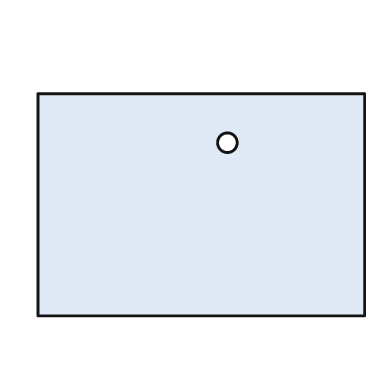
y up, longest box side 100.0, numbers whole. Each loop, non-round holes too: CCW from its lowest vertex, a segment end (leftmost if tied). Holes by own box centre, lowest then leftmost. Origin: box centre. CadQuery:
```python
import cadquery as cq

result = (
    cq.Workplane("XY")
    .moveTo(-50.0, -34.0)
    .lineTo(50.0, -34.0)
    .lineTo(50.0, 34.0)
    .lineTo(-50.0, 34.0)
    .close()
    .moveTo(8.0, 19.0)
    .circle(3.0)
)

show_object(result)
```